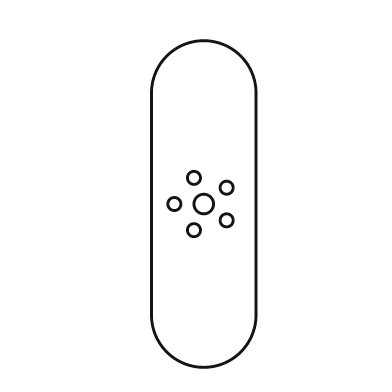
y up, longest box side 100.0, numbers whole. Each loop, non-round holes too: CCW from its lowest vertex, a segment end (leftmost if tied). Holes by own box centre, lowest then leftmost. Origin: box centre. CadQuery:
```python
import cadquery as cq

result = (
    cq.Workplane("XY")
    .moveTo(-16.0, -34.0)
    .threePointArc((0.0, -50.0), (16.0, -34.0))
    .lineTo(16.0, 34.0)
    .threePointArc((0.0, 50.0), (-16.0, 34.0))
    .close()
    .moveTo(-3.0, -8.0)
    .circle(2.0)
    .moveTo(7.0, -5.0)
    .circle(2.0)
    .moveTo(-9.0, 0.0)
    .circle(2.0)
    .moveTo(0.0, 0.0)
    .circle(3.0)
    .moveTo(7.0, 5.0)
    .circle(2.0)
    .moveTo(-3.0, 8.0)
    .circle(2.0)
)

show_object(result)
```